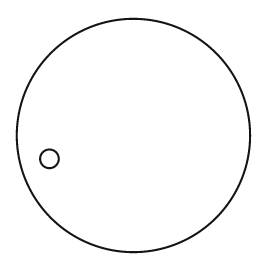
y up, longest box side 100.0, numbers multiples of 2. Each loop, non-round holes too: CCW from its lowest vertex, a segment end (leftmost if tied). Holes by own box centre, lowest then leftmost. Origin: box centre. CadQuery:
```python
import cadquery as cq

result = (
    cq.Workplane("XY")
    .moveTo(0.0, 0.0)
    .circle(50.0)
    .moveTo(-36.0, -10.0)
    .circle(4.0)
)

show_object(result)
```